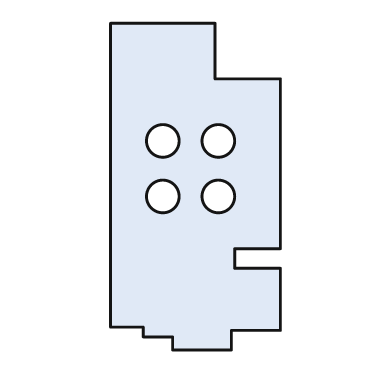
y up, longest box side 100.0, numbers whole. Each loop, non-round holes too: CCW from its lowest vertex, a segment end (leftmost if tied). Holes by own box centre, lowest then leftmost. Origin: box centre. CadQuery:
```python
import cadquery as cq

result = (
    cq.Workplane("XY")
    .moveTo(-7.0, -50.0)
    .lineTo(11.0, -50.0)
    .lineTo(11.0, -44.0)
    .lineTo(26.0, -44.0)
    .lineTo(26.0, -25.0)
    .lineTo(12.0, -25.0)
    .lineTo(12.0, -19.0)
    .lineTo(26.0, -19.0)
    .lineTo(26.0, 33.0)
    .lineTo(6.0, 33.0)
    .lineTo(6.0, 50.0)
    .lineTo(-26.0, 50.0)
    .lineTo(-26.0, -43.0)
    .lineTo(-16.0, -43.0)
    .lineTo(-16.0, -46.0)
    .lineTo(-7.0, -46.0)
    .close()
    .moveTo(-10.0, -3.0)
    .circle(5.0)
    .moveTo(7.0, -3.0)
    .circle(5.0)
    .moveTo(-10.0, 14.0)
    .circle(5.0)
    .moveTo(7.0, 14.0)
    .circle(5.0)
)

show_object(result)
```